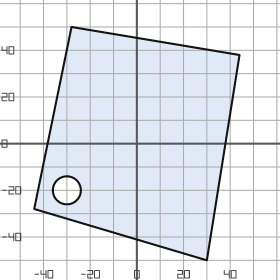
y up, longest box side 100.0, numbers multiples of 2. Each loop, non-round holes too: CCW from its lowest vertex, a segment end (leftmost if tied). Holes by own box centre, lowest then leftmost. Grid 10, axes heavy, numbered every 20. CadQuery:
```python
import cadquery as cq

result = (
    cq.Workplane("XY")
    .moveTo(30.0, -50.0)
    .lineTo(44.0, 38.0)
    .lineTo(-28.0, 50.0)
    .lineTo(-44.0, -28.0)
    .close()
    .moveTo(-30.0, -20.0)
    .circle(6.0)
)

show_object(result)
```